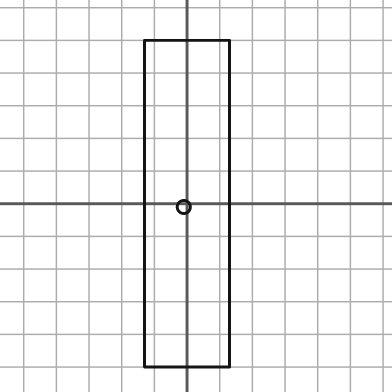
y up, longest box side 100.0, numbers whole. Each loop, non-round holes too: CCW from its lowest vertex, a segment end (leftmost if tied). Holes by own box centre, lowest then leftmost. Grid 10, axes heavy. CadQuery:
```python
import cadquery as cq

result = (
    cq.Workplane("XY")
    .moveTo(-13.0, -50.0)
    .lineTo(13.0, -50.0)
    .lineTo(13.0, 50.0)
    .lineTo(-13.0, 50.0)
    .close()
    .moveTo(-1.0, -1.0)
    .circle(2.0)
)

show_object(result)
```